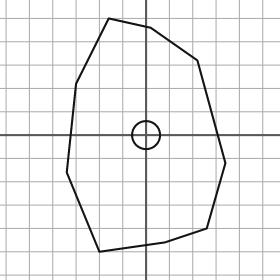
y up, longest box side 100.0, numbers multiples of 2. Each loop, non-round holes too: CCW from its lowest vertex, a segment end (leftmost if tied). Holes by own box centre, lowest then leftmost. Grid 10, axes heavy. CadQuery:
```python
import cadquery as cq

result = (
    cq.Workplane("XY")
    .moveTo(-20.0, -50.0)
    .lineTo(8.0, -46.0)
    .lineTo(26.0, -40.0)
    .lineTo(34.0, -12.0)
    .lineTo(22.0, 32.0)
    .lineTo(2.0, 46.0)
    .lineTo(-16.0, 50.0)
    .lineTo(-30.0, 22.0)
    .lineTo(-34.0, -16.0)
    .close()
    .moveTo(0.0, 0.0)
    .circle(6.0)
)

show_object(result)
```